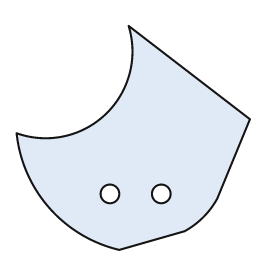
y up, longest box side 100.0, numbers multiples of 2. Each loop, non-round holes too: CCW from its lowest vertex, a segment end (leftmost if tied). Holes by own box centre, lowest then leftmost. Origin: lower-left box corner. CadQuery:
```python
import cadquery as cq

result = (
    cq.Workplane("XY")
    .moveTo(44.0, 0.0)
    .lineTo(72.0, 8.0)
    .threePointArc((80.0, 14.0), (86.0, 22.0))
    .lineTo(100.0, 56.0)
    .lineTo(48.0, 96.0)
    .threePointArc((38.0, 58.0), (0.0, 50.0))
    .threePointArc((14.0, 18.0), (44.0, 0.0))
    .close()
    .moveTo(40.0, 24.0)
    .circle(4.0)
    .moveTo(62.0, 24.0)
    .circle(4.0)
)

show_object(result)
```